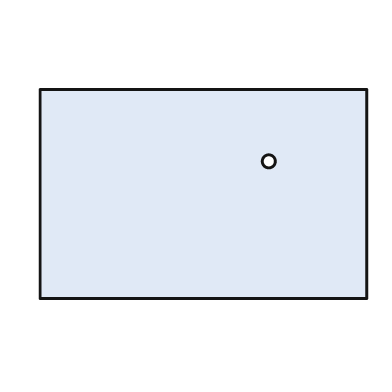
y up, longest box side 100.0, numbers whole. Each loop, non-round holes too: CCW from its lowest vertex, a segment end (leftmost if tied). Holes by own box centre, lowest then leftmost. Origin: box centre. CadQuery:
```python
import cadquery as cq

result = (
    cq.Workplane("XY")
    .moveTo(-50.0, -32.0)
    .lineTo(50.0, -32.0)
    .lineTo(50.0, 32.0)
    .lineTo(-50.0, 32.0)
    .close()
    .moveTo(20.0, 10.0)
    .circle(2.0)
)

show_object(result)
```